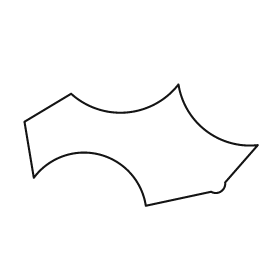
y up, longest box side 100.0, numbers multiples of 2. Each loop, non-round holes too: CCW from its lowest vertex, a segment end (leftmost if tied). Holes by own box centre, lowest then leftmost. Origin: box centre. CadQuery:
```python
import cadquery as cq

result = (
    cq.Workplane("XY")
    .moveTo(2.0, -26.0)
    .lineTo(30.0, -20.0)
    .threePointArc((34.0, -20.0), (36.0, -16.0))
    .lineTo(50.0, 0.0)
    .threePointArc((28.0, 6.0), (16.0, 26.0))
    .threePointArc((-6.0, 14.0), (-30.0, 22.0))
    .lineTo(-50.0, 10.0)
    .lineTo(-46.0, -14.0)
    .threePointArc((-18.0, -4.0), (2.0, -26.0))
    .close()
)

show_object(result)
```